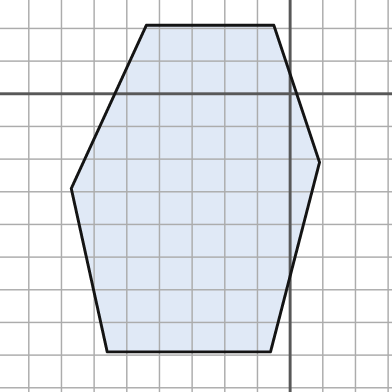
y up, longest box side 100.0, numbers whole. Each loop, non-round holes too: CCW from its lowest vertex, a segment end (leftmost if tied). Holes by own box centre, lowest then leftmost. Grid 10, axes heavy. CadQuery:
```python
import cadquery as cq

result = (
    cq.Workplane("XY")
    .moveTo(-56.0, -79.0)
    .lineTo(-6.0, -79.0)
    .lineTo(9.0, -21.0)
    .lineTo(-5.0, 21.0)
    .lineTo(-44.0, 21.0)
    .lineTo(-67.0, -29.0)
    .close()
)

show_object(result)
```